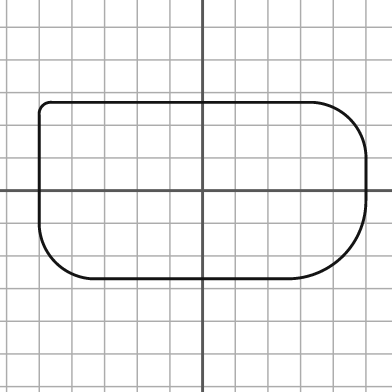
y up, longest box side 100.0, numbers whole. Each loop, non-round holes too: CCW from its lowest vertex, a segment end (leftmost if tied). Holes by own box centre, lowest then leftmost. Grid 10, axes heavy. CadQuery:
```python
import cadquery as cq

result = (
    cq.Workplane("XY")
    .moveTo(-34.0, -27.0)
    .lineTo(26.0, -27.0)
    .threePointArc((43.0, -20.0), (50.0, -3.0))
    .lineTo(50.0, 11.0)
    .threePointArc((45.0, 22.0), (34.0, 27.0))
    .lineTo(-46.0, 27.0)
    .threePointArc((-49.0, 26.0), (-50.0, 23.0))
    .lineTo(-50.0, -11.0)
    .threePointArc((-45.0, -22.0), (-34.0, -27.0))
    .close()
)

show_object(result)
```